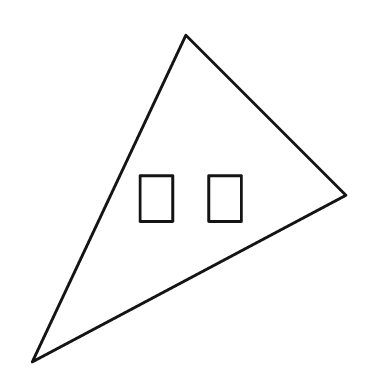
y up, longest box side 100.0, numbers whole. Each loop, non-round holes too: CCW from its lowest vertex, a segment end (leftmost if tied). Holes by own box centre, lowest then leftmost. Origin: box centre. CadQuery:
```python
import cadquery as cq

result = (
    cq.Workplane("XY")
    .moveTo(-48.0, -50.0)
    .lineTo(48.0, 1.0)
    .lineTo(-1.0, 50.0)
    .close()
    .moveTo(-15.0, -7.0)
    .lineTo(-5.0, -7.0)
    .lineTo(-5.0, 7.0)
    .lineTo(-15.0, 7.0)
    .close()
    .moveTo(6.0, -7.0)
    .lineTo(16.0, -7.0)
    .lineTo(16.0, 7.0)
    .lineTo(6.0, 7.0)
    .close()
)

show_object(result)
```